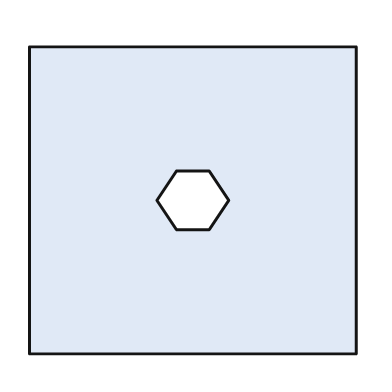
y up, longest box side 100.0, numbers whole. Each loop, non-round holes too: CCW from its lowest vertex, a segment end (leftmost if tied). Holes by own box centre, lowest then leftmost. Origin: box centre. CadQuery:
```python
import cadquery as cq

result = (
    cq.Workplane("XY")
    .moveTo(-50.0, -47.0)
    .lineTo(50.0, -47.0)
    .lineTo(50.0, 47.0)
    .lineTo(-50.0, 47.0)
    .close()
    .moveTo(-5.0, -9.0)
    .lineTo(5.0, -9.0)
    .lineTo(11.0, 0.0)
    .lineTo(5.0, 9.0)
    .lineTo(-5.0, 9.0)
    .lineTo(-11.0, 0.0)
    .close()
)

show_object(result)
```